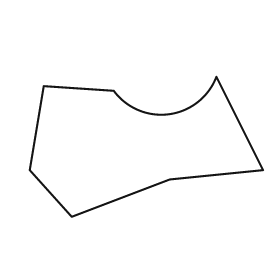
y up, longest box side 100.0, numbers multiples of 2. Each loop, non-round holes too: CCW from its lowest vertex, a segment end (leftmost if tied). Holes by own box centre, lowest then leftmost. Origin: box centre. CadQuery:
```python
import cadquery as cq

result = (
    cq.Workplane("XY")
    .moveTo(-32.0, -30.0)
    .lineTo(10.0, -14.0)
    .lineTo(50.0, -10.0)
    .lineTo(30.0, 30.0)
    .threePointArc((10.0, 14.0), (-14.0, 24.0))
    .lineTo(-44.0, 26.0)
    .lineTo(-50.0, -10.0)
    .close()
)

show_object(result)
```